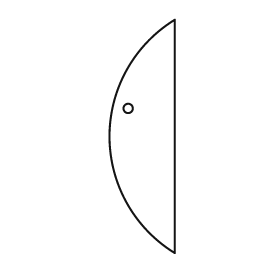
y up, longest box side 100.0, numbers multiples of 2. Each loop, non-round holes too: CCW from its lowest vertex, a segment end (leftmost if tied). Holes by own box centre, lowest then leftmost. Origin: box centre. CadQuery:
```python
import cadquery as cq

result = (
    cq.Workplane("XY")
    .moveTo(14.0, -50.0)
    .lineTo(14.0, 50.0)
    .threePointArc((-14.0, 0.0), (14.0, -50.0))
    .close()
    .moveTo(-6.0, 12.0)
    .circle(2.0)
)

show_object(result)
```